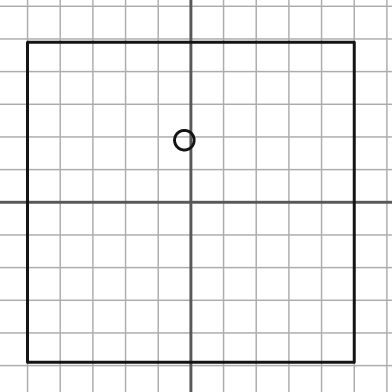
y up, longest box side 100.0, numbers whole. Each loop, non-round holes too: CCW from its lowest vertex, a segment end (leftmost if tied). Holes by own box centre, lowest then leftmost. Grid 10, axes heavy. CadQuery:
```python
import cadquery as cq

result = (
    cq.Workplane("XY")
    .moveTo(-50.0, -49.0)
    .lineTo(50.0, -49.0)
    .lineTo(50.0, 49.0)
    .lineTo(-50.0, 49.0)
    .close()
    .moveTo(-2.0, 19.0)
    .circle(3.0)
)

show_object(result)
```